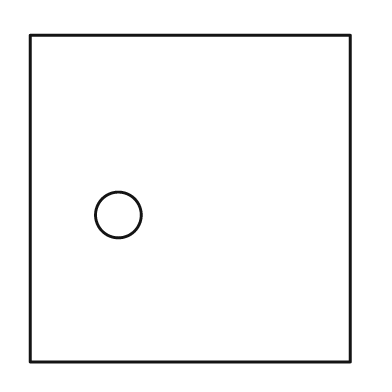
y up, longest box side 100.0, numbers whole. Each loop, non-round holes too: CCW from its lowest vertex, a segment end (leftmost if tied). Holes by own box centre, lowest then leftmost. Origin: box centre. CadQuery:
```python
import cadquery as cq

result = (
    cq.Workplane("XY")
    .moveTo(-49.0, -50.0)
    .lineTo(49.0, -50.0)
    .lineTo(49.0, 50.0)
    .lineTo(-49.0, 50.0)
    .close()
    .moveTo(-22.0, -5.0)
    .circle(7.0)
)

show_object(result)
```